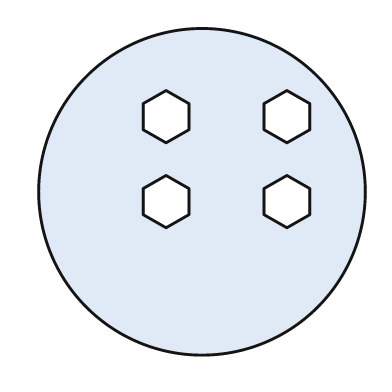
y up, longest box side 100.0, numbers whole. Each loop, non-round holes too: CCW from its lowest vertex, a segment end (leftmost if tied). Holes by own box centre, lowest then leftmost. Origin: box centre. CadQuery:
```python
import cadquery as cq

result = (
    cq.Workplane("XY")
    .moveTo(0.0, 0.0)
    .circle(50.0)
    .moveTo(-11.0, -11.0)
    .lineTo(-4.0, -7.0)
    .lineTo(-4.0, 1.0)
    .lineTo(-11.0, 5.0)
    .lineTo(-18.0, 1.0)
    .lineTo(-18.0, -7.0)
    .close()
    .moveTo(26.0, -11.0)
    .lineTo(33.0, -7.0)
    .lineTo(33.0, 1.0)
    .lineTo(26.0, 5.0)
    .lineTo(19.0, 1.0)
    .lineTo(19.0, -7.0)
    .close()
    .moveTo(-11.0, 15.0)
    .lineTo(-4.0, 19.0)
    .lineTo(-4.0, 27.0)
    .lineTo(-11.0, 31.0)
    .lineTo(-18.0, 27.0)
    .lineTo(-18.0, 19.0)
    .close()
    .moveTo(26.0, 15.0)
    .lineTo(33.0, 19.0)
    .lineTo(33.0, 27.0)
    .lineTo(26.0, 31.0)
    .lineTo(19.0, 27.0)
    .lineTo(19.0, 19.0)
    .close()
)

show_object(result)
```